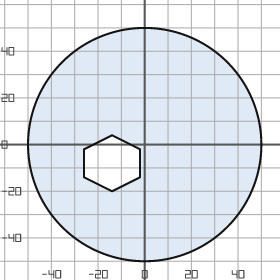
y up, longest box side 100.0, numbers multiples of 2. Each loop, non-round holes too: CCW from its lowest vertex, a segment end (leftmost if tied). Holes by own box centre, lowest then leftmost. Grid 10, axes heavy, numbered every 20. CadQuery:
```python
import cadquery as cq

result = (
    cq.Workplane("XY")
    .moveTo(0.0, 0.0)
    .circle(50.0)
    .moveTo(-14.0, -20.0)
    .lineTo(-2.0, -14.0)
    .lineTo(-2.0, -2.0)
    .lineTo(-14.0, 4.0)
    .lineTo(-26.0, -2.0)
    .lineTo(-26.0, -14.0)
    .close()
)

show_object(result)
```